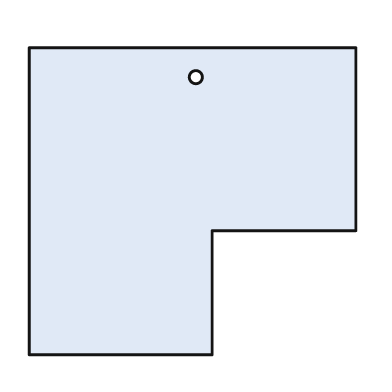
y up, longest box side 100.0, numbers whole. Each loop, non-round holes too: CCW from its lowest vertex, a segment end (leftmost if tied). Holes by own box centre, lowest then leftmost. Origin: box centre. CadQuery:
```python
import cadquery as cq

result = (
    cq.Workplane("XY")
    .moveTo(-50.0, -47.0)
    .lineTo(6.0, -47.0)
    .lineTo(6.0, -9.0)
    .lineTo(50.0, -9.0)
    .lineTo(50.0, 47.0)
    .lineTo(-50.0, 47.0)
    .close()
    .moveTo(1.0, 38.0)
    .circle(2.0)
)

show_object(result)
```